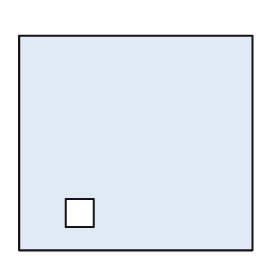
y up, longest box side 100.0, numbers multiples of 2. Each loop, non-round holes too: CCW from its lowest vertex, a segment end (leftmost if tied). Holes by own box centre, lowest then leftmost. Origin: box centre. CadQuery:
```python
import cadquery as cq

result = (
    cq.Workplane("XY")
    .moveTo(-50.0, -46.0)
    .lineTo(50.0, -46.0)
    .lineTo(50.0, 46.0)
    .lineTo(-50.0, 46.0)
    .close()
    .moveTo(-30.0, -36.0)
    .lineTo(-18.0, -36.0)
    .lineTo(-18.0, -24.0)
    .lineTo(-30.0, -24.0)
    .close()
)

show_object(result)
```